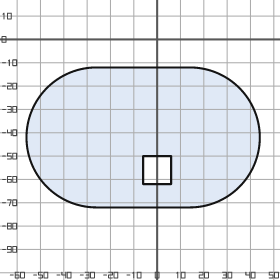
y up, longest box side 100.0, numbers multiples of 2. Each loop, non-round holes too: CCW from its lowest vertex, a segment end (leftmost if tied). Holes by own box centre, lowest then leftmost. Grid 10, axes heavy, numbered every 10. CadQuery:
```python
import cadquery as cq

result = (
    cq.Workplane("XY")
    .moveTo(-26.0, -72.0)
    .lineTo(14.0, -72.0)
    .threePointArc((44.0, -42.0), (14.0, -12.0))
    .lineTo(-26.0, -12.0)
    .threePointArc((-56.0, -42.0), (-26.0, -72.0))
    .close()
    .moveTo(-6.0, -62.0)
    .lineTo(6.0, -62.0)
    .lineTo(6.0, -50.0)
    .lineTo(-6.0, -50.0)
    .close()
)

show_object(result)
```